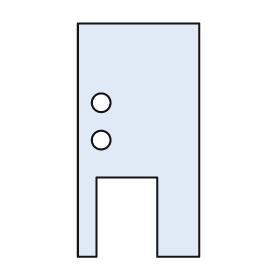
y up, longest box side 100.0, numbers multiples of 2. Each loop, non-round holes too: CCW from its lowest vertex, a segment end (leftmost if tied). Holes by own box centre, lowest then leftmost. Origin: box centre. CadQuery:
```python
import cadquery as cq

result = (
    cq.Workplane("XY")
    .moveTo(-26.0, -50.0)
    .lineTo(-18.0, -50.0)
    .lineTo(-18.0, -16.0)
    .lineTo(8.0, -16.0)
    .lineTo(8.0, -50.0)
    .lineTo(26.0, -50.0)
    .lineTo(26.0, 50.0)
    .lineTo(-26.0, 50.0)
    .close()
    .moveTo(-16.0, 0.0)
    .circle(4.0)
    .moveTo(-16.0, 16.0)
    .circle(4.0)
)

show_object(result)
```